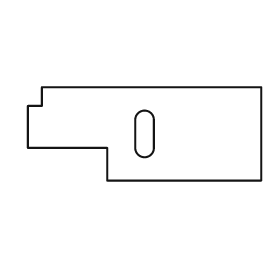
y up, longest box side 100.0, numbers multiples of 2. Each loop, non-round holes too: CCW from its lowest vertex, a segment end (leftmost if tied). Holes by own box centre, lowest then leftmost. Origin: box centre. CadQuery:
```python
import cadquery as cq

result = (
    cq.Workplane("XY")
    .moveTo(-16.0, -20.0)
    .lineTo(50.0, -20.0)
    .lineTo(50.0, 20.0)
    .lineTo(-44.0, 20.0)
    .lineTo(-44.0, 12.0)
    .lineTo(-50.0, 12.0)
    .lineTo(-50.0, -6.0)
    .lineTo(-16.0, -6.0)
    .close()
    .moveTo(-4.0, -6.0)
    .threePointArc((0.0, -10.0), (4.0, -6.0))
    .lineTo(4.0, 6.0)
    .threePointArc((0.0, 10.0), (-4.0, 6.0))
    .close()
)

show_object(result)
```